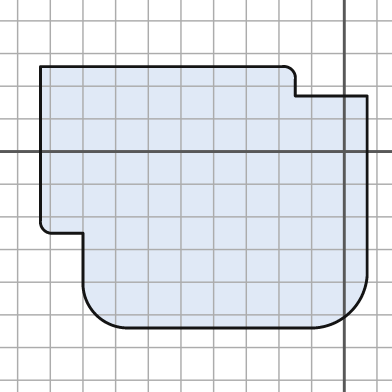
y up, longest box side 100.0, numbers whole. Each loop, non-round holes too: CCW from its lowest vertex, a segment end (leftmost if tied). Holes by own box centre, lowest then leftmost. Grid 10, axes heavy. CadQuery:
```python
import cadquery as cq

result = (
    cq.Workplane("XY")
    .moveTo(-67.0, -54.0)
    .lineTo(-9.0, -54.0)
    .threePointArc((2.0, -49.0), (7.0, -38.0))
    .lineTo(7.0, 17.0)
    .lineTo(-15.0, 17.0)
    .lineTo(-15.0, 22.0)
    .threePointArc((-16.0, 25.0), (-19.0, 26.0))
    .lineTo(-93.0, 26.0)
    .lineTo(-93.0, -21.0)
    .threePointArc((-92.0, -24.0), (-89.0, -25.0))
    .lineTo(-80.0, -25.0)
    .lineTo(-80.0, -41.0)
    .threePointArc((-76.0, -50.0), (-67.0, -54.0))
    .close()
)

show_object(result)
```